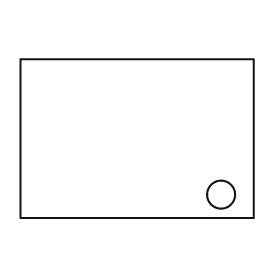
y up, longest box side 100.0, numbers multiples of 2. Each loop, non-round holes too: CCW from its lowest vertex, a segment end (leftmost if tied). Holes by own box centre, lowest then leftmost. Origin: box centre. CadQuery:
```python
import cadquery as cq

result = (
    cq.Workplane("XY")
    .moveTo(-50.0, -34.0)
    .lineTo(50.0, -34.0)
    .lineTo(50.0, 34.0)
    .lineTo(-50.0, 34.0)
    .close()
    .moveTo(36.0, -24.0)
    .circle(6.0)
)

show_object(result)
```